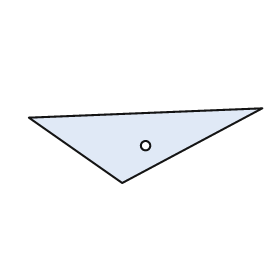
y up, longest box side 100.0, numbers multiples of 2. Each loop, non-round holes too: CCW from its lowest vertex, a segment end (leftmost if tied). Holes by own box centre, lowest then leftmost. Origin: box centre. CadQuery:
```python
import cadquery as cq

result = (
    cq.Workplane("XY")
    .moveTo(-10.0, -16.0)
    .lineTo(50.0, 16.0)
    .lineTo(-50.0, 12.0)
    .close()
    .moveTo(0.0, 0.0)
    .circle(2.0)
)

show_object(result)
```